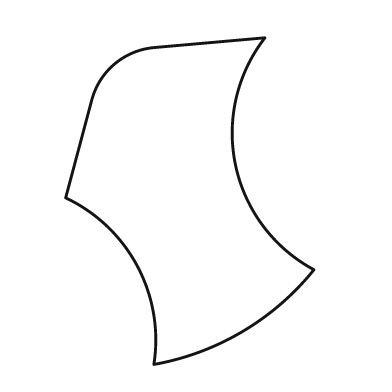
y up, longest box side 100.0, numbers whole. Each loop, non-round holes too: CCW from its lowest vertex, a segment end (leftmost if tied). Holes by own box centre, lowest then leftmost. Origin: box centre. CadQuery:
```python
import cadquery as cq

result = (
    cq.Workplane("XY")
    .moveTo(-11.0, -50.0)
    .threePointArc((16.0, -40.0), (38.0, -21.0))
    .threePointArc((14.0, 11.0), (23.0, 50.0))
    .lineTo(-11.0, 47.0)
    .threePointArc((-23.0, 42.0), (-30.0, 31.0))
    .lineTo(-38.0, 1.0)
    .threePointArc((-16.0, -20.0), (-11.0, -50.0))
    .close()
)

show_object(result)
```